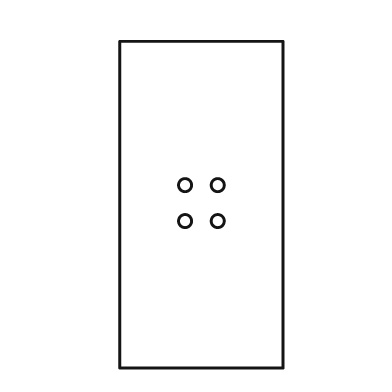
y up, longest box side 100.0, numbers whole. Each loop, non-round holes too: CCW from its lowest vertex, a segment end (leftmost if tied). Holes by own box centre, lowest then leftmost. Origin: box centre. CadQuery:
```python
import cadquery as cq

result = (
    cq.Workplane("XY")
    .moveTo(-25.0, -50.0)
    .lineTo(25.0, -50.0)
    .lineTo(25.0, 50.0)
    .lineTo(-25.0, 50.0)
    .close()
    .moveTo(-5.0, -5.0)
    .circle(2.0)
    .moveTo(5.0, -5.0)
    .circle(2.0)
    .moveTo(-5.0, 6.0)
    .circle(2.0)
    .moveTo(5.0, 6.0)
    .circle(2.0)
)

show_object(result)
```